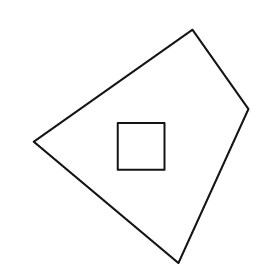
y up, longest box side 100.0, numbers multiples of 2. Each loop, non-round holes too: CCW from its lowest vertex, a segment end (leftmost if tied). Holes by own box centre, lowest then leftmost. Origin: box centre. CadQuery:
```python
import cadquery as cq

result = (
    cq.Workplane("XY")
    .moveTo(16.0, -50.0)
    .lineTo(46.0, 16.0)
    .lineTo(22.0, 50.0)
    .lineTo(-46.0, 2.0)
    .close()
    .moveTo(-10.0, -10.0)
    .lineTo(10.0, -10.0)
    .lineTo(10.0, 10.0)
    .lineTo(-10.0, 10.0)
    .close()
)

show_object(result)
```